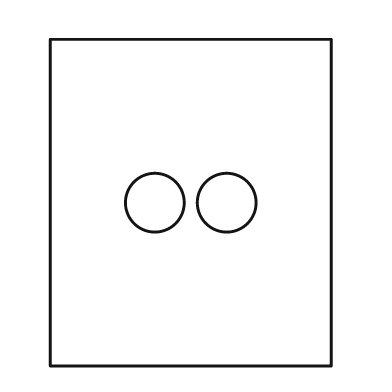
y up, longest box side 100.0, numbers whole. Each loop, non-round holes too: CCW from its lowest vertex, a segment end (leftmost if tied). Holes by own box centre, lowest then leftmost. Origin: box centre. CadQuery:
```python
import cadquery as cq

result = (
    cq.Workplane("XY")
    .moveTo(-43.0, -50.0)
    .lineTo(43.0, -50.0)
    .lineTo(43.0, 50.0)
    .lineTo(-43.0, 50.0)
    .close()
    .moveTo(-11.0, 0.0)
    .circle(9.0)
    .moveTo(11.0, 0.0)
    .circle(9.0)
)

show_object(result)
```